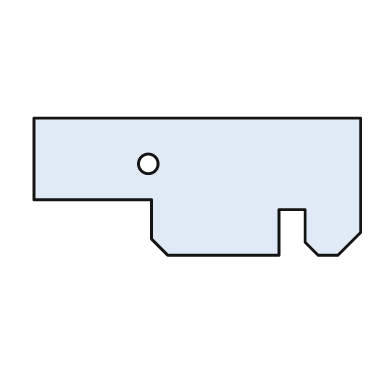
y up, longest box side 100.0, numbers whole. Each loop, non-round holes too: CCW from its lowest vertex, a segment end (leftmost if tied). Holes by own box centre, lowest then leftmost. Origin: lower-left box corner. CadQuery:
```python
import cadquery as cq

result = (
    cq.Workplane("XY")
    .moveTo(41.0, 0.0)
    .lineTo(75.0, 0.0)
    .lineTo(75.0, 14.0)
    .lineTo(83.0, 14.0)
    .lineTo(83.0, 4.0)
    .lineTo(87.0, 0.0)
    .lineTo(93.0, 0.0)
    .lineTo(100.0, 7.0)
    .lineTo(100.0, 42.0)
    .lineTo(0.0, 42.0)
    .lineTo(0.0, 17.0)
    .lineTo(36.0, 17.0)
    .lineTo(36.0, 5.0)
    .close()
    .moveTo(35.0, 28.0)
    .circle(3.0)
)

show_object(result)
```